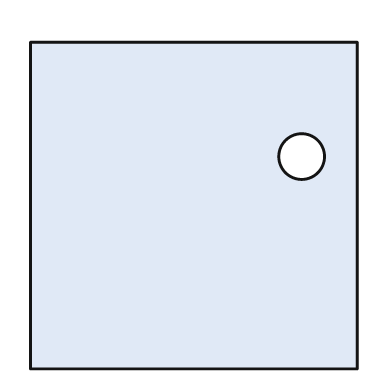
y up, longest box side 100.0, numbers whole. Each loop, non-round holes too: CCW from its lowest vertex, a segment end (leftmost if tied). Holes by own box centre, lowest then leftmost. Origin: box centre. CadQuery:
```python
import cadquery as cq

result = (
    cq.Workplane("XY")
    .moveTo(-50.0, -50.0)
    .lineTo(50.0, -50.0)
    .lineTo(50.0, 50.0)
    .lineTo(-50.0, 50.0)
    .close()
    .moveTo(33.0, 15.0)
    .circle(7.0)
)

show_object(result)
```